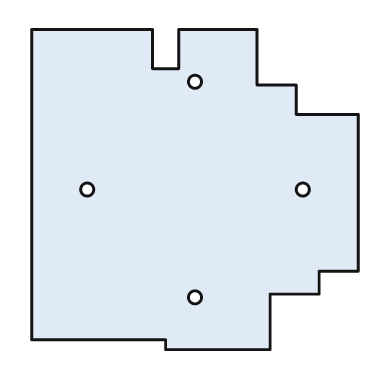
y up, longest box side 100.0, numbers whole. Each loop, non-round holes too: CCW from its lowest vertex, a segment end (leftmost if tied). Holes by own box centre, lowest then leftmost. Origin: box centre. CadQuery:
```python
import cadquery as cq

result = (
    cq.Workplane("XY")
    .moveTo(-9.0, -49.0)
    .lineTo(23.0, -49.0)
    .lineTo(23.0, -32.0)
    .lineTo(38.0, -32.0)
    .lineTo(38.0, -25.0)
    .lineTo(50.0, -25.0)
    .lineTo(50.0, 23.0)
    .lineTo(31.0, 23.0)
    .lineTo(31.0, 32.0)
    .lineTo(19.0, 32.0)
    .lineTo(19.0, 49.0)
    .lineTo(-5.0, 49.0)
    .lineTo(-5.0, 37.0)
    .lineTo(-13.0, 37.0)
    .lineTo(-13.0, 49.0)
    .lineTo(-50.0, 49.0)
    .lineTo(-50.0, -46.0)
    .lineTo(-9.0, -46.0)
    .close()
    .moveTo(0.0, -33.0)
    .circle(2.0)
    .moveTo(-33.0, 0.0)
    .circle(2.0)
    .moveTo(33.0, 0.0)
    .circle(2.0)
    .moveTo(0.0, 33.0)
    .circle(2.0)
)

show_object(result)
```